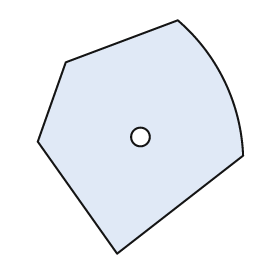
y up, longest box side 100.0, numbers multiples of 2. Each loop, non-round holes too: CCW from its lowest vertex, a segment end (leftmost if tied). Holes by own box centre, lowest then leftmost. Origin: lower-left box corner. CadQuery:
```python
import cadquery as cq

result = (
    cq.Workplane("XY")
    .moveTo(34.0, 0.0)
    .lineTo(88.0, 42.0)
    .threePointArc((80.0, 74.0), (60.0, 100.0))
    .lineTo(12.0, 82.0)
    .lineTo(0.0, 48.0)
    .close()
    .moveTo(44.0, 50.0)
    .circle(4.0)
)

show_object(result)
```